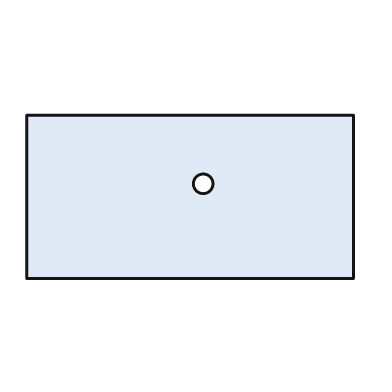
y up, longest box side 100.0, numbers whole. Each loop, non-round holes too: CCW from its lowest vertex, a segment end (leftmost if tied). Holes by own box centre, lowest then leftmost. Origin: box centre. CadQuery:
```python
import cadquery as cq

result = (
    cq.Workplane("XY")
    .moveTo(-50.0, -25.0)
    .lineTo(50.0, -25.0)
    .lineTo(50.0, 25.0)
    .lineTo(-50.0, 25.0)
    .close()
    .moveTo(4.0, 4.0)
    .circle(3.0)
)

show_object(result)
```